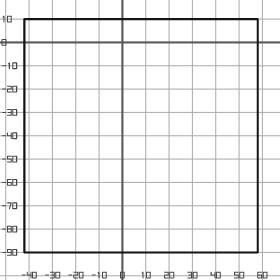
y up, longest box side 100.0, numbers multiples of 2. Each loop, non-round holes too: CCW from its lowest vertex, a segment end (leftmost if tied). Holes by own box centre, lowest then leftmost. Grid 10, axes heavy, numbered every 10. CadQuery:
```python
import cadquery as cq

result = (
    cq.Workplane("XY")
    .moveTo(-42.0, -90.0)
    .lineTo(58.0, -90.0)
    .lineTo(58.0, 10.0)
    .lineTo(-42.0, 10.0)
    .close()
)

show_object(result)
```